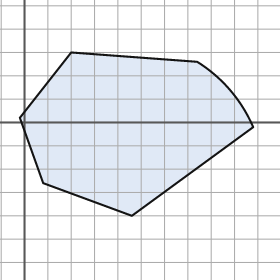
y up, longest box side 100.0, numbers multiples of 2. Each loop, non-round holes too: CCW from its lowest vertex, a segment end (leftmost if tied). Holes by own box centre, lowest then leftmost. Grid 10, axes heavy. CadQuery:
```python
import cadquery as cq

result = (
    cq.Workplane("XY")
    .moveTo(46.0, -40.0)
    .lineTo(98.0, -2.0)
    .threePointArc((88.0, 14.0), (74.0, 26.0))
    .lineTo(20.0, 30.0)
    .lineTo(-2.0, 2.0)
    .lineTo(8.0, -26.0)
    .close()
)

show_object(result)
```